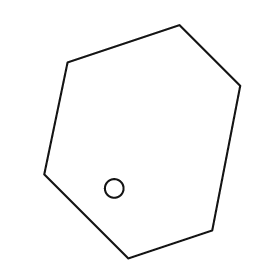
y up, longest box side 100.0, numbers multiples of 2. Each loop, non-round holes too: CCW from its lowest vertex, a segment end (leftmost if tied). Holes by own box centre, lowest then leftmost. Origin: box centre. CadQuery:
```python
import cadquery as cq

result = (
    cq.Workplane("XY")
    .moveTo(-6.0, -50.0)
    .lineTo(30.0, -38.0)
    .lineTo(42.0, 24.0)
    .lineTo(16.0, 50.0)
    .lineTo(-32.0, 34.0)
    .lineTo(-42.0, -14.0)
    .close()
    .moveTo(-12.0, -20.0)
    .circle(4.0)
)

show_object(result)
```